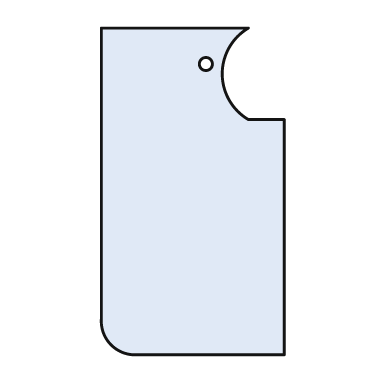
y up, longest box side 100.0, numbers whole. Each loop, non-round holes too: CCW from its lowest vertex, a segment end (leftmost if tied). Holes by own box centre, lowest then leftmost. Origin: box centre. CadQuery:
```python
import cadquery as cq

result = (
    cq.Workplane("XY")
    .moveTo(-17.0, -50.0)
    .lineTo(28.0, -50.0)
    .lineTo(28.0, 22.0)
    .lineTo(17.0, 22.0)
    .threePointArc((9.0, 36.0), (17.0, 50.0))
    .lineTo(-28.0, 50.0)
    .lineTo(-28.0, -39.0)
    .threePointArc((-25.0, -47.0), (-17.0, -50.0))
    .close()
    .moveTo(4.0, 39.0)
    .circle(2.0)
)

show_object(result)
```